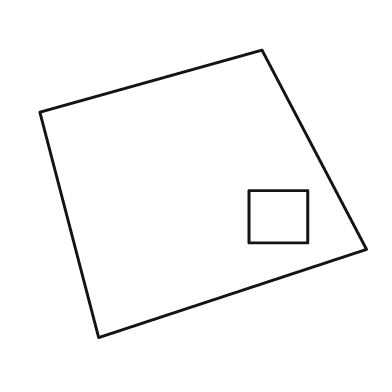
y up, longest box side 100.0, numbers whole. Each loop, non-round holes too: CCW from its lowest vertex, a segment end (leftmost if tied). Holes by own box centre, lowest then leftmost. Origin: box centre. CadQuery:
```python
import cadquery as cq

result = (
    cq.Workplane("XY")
    .moveTo(-32.0, -44.0)
    .lineTo(50.0, -17.0)
    .lineTo(18.0, 44.0)
    .lineTo(-50.0, 25.0)
    .close()
    .moveTo(14.0, -15.0)
    .lineTo(32.0, -15.0)
    .lineTo(32.0, 1.0)
    .lineTo(14.0, 1.0)
    .close()
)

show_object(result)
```